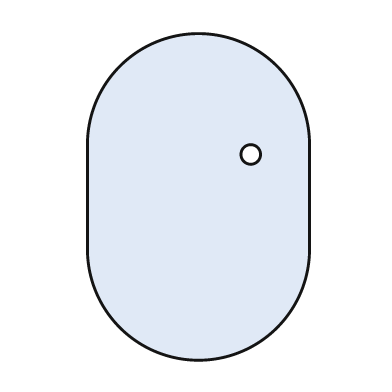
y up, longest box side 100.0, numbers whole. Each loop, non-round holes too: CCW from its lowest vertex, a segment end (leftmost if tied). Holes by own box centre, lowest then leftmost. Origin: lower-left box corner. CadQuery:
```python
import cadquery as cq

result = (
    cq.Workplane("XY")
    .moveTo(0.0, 34.0)
    .threePointArc((34.0, 0.0), (68.0, 34.0))
    .lineTo(68.0, 66.0)
    .threePointArc((34.0, 100.0), (0.0, 66.0))
    .close()
    .moveTo(50.0, 63.0)
    .circle(3.0)
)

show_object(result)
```